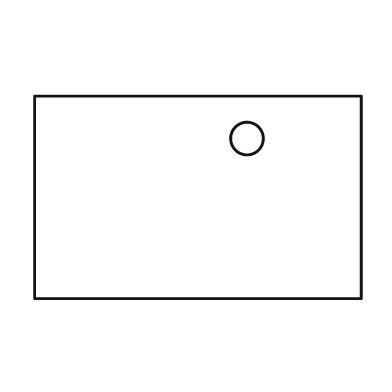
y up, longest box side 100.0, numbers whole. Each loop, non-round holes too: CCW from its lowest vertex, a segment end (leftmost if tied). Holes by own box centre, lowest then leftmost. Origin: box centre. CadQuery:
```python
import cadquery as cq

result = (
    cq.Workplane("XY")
    .moveTo(-50.0, -31.0)
    .lineTo(50.0, -31.0)
    .lineTo(50.0, 31.0)
    .lineTo(-50.0, 31.0)
    .close()
    .moveTo(15.0, 18.0)
    .circle(5.0)
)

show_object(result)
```